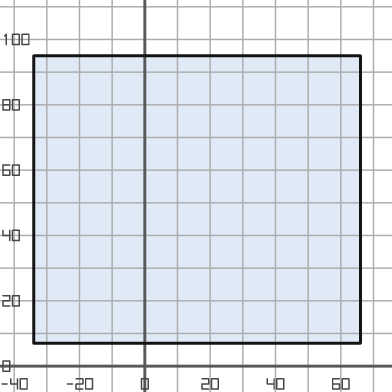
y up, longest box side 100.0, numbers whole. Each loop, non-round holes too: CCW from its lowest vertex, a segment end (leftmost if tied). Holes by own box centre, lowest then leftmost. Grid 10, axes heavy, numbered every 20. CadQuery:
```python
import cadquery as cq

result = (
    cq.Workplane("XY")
    .moveTo(-34.0, 7.0)
    .lineTo(66.0, 7.0)
    .lineTo(66.0, 95.0)
    .lineTo(-34.0, 95.0)
    .close()
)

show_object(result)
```